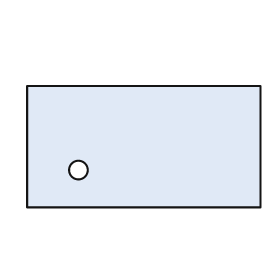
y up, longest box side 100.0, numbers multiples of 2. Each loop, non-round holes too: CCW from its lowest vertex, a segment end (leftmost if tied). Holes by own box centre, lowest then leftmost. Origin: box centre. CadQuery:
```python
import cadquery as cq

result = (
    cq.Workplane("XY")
    .moveTo(-50.0, -26.0)
    .lineTo(50.0, -26.0)
    .lineTo(50.0, 26.0)
    .lineTo(-50.0, 26.0)
    .close()
    .moveTo(-28.0, -10.0)
    .circle(4.0)
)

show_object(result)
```